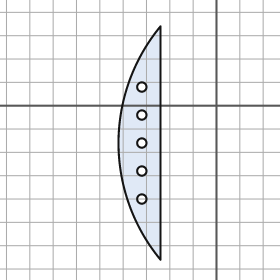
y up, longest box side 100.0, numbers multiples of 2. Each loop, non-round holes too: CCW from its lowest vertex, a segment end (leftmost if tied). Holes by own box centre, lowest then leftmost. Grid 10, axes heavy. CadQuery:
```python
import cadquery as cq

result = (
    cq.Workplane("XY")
    .moveTo(-24.0, -66.0)
    .lineTo(-24.0, 34.0)
    .threePointArc((-42.0, -16.0), (-24.0, -66.0))
    .close()
    .moveTo(-32.0, -40.0)
    .circle(2.0)
    .moveTo(-32.0, -28.0)
    .circle(2.0)
    .moveTo(-32.0, -16.0)
    .circle(2.0)
    .moveTo(-32.0, -4.0)
    .circle(2.0)
    .moveTo(-32.0, 8.0)
    .circle(2.0)
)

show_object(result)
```